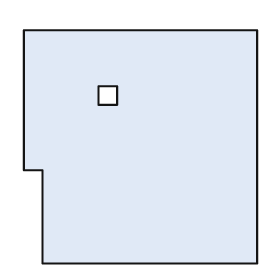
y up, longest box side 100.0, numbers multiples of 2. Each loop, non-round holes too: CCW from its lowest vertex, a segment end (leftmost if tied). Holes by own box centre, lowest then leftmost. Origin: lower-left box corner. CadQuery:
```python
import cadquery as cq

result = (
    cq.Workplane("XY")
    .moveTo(8.0, 0.0)
    .lineTo(100.0, 0.0)
    .lineTo(100.0, 100.0)
    .lineTo(0.0, 100.0)
    .lineTo(0.0, 40.0)
    .lineTo(8.0, 40.0)
    .close()
    .moveTo(32.0, 68.0)
    .lineTo(40.0, 68.0)
    .lineTo(40.0, 76.0)
    .lineTo(32.0, 76.0)
    .close()
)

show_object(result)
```